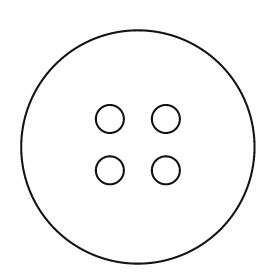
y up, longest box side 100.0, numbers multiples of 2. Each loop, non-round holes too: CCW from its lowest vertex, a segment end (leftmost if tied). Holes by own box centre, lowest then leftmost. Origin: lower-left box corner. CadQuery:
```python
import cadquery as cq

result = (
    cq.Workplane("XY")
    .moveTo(50.0, 50.0)
    .circle(50.0)
    .moveTo(38.0, 40.0)
    .circle(6.0)
    .moveTo(62.0, 40.0)
    .circle(6.0)
    .moveTo(38.0, 62.0)
    .circle(6.0)
    .moveTo(62.0, 62.0)
    .circle(6.0)
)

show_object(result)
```